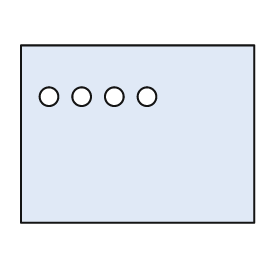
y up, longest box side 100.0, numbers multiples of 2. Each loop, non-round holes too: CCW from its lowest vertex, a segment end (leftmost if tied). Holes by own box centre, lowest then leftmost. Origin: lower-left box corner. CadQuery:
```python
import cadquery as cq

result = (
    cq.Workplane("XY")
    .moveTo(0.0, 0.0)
    .lineTo(100.0, 0.0)
    .lineTo(100.0, 76.0)
    .lineTo(0.0, 76.0)
    .close()
    .moveTo(12.0, 54.0)
    .circle(4.0)
    .moveTo(26.0, 54.0)
    .circle(4.0)
    .moveTo(40.0, 54.0)
    .circle(4.0)
    .moveTo(54.0, 54.0)
    .circle(4.0)
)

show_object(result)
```